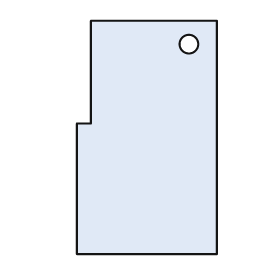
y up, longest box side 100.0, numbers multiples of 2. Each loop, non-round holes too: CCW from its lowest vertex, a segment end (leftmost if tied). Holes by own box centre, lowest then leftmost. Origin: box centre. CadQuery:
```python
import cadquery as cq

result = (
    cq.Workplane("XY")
    .moveTo(-30.0, -50.0)
    .lineTo(30.0, -50.0)
    .lineTo(30.0, 50.0)
    .lineTo(-24.0, 50.0)
    .lineTo(-24.0, 6.0)
    .lineTo(-30.0, 6.0)
    .close()
    .moveTo(18.0, 40.0)
    .circle(4.0)
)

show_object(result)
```